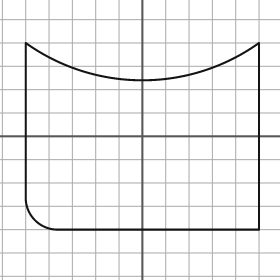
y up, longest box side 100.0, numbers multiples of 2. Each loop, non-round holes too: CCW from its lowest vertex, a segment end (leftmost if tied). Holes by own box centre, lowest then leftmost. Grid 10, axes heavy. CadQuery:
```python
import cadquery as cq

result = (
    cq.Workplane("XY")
    .moveTo(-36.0, -40.0)
    .lineTo(50.0, -40.0)
    .lineTo(50.0, 40.0)
    .threePointArc((0.0, 24.0), (-50.0, 40.0))
    .lineTo(-50.0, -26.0)
    .threePointArc((-46.0, -36.0), (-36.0, -40.0))
    .close()
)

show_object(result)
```